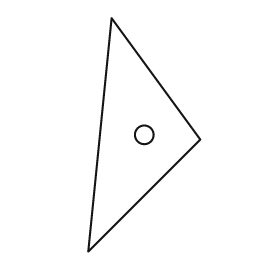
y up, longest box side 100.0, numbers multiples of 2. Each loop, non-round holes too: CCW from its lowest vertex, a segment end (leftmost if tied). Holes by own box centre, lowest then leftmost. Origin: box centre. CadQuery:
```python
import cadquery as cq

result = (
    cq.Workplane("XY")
    .moveTo(-24.0, -50.0)
    .lineTo(24.0, -2.0)
    .lineTo(-14.0, 50.0)
    .close()
    .moveTo(0.0, 0.0)
    .circle(4.0)
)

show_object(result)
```